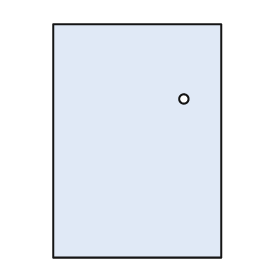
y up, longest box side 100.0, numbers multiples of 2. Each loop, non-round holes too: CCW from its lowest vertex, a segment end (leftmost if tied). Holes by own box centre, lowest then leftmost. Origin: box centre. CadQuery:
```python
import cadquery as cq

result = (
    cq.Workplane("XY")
    .moveTo(-36.0, -50.0)
    .lineTo(36.0, -50.0)
    .lineTo(36.0, 50.0)
    .lineTo(-36.0, 50.0)
    .close()
    .moveTo(20.0, 18.0)
    .circle(2.0)
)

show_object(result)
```